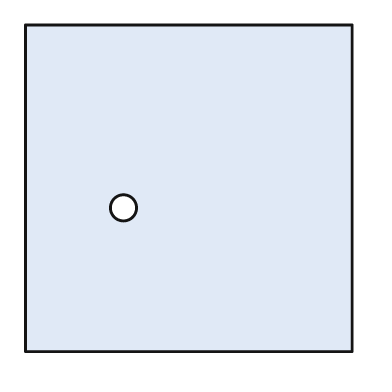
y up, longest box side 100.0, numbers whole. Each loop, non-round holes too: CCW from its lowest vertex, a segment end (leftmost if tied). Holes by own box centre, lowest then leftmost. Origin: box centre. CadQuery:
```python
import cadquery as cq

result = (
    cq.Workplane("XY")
    .moveTo(-50.0, -50.0)
    .lineTo(50.0, -50.0)
    .lineTo(50.0, 50.0)
    .lineTo(-50.0, 50.0)
    .close()
    .moveTo(-20.0, -6.0)
    .circle(4.0)
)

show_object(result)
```